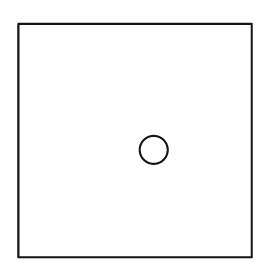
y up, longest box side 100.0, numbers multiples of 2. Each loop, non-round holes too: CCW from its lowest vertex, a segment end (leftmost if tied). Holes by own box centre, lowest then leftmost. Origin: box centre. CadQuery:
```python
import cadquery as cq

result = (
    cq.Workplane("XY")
    .moveTo(-50.0, -50.0)
    .lineTo(50.0, -50.0)
    .lineTo(50.0, 50.0)
    .lineTo(-50.0, 50.0)
    .close()
    .moveTo(8.0, -4.0)
    .circle(6.0)
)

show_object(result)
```